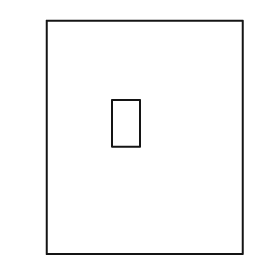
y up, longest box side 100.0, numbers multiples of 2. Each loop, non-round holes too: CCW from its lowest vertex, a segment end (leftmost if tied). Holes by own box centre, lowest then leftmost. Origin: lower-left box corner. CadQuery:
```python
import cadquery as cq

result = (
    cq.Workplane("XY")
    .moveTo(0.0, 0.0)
    .lineTo(84.0, 0.0)
    .lineTo(84.0, 100.0)
    .lineTo(0.0, 100.0)
    .close()
    .moveTo(28.0, 46.0)
    .lineTo(40.0, 46.0)
    .lineTo(40.0, 66.0)
    .lineTo(28.0, 66.0)
    .close()
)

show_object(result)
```